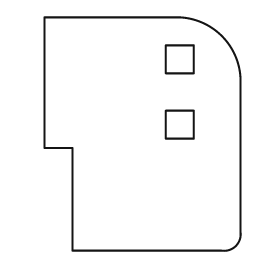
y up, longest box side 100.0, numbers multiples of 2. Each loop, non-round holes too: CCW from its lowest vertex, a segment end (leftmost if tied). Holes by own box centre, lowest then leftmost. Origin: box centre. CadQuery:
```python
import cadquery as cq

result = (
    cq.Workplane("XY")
    .moveTo(-30.0, -50.0)
    .lineTo(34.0, -50.0)
    .threePointArc((40.0, -48.0), (42.0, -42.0))
    .lineTo(42.0, 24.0)
    .threePointArc((34.0, 42.0), (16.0, 50.0))
    .lineTo(-42.0, 50.0)
    .lineTo(-42.0, -6.0)
    .lineTo(-30.0, -6.0)
    .close()
    .moveTo(10.0, -2.0)
    .lineTo(22.0, -2.0)
    .lineTo(22.0, 10.0)
    .lineTo(10.0, 10.0)
    .close()
    .moveTo(10.0, 26.0)
    .lineTo(22.0, 26.0)
    .lineTo(22.0, 38.0)
    .lineTo(10.0, 38.0)
    .close()
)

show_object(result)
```